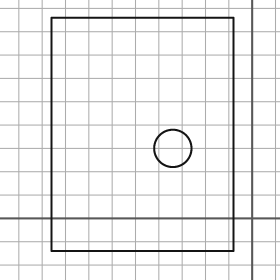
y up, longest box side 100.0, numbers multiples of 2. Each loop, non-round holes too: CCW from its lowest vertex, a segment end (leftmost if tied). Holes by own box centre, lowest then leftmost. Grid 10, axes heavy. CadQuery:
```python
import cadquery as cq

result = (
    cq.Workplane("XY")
    .moveTo(-86.0, -14.0)
    .lineTo(-8.0, -14.0)
    .lineTo(-8.0, 86.0)
    .lineTo(-86.0, 86.0)
    .close()
    .moveTo(-34.0, 30.0)
    .circle(8.0)
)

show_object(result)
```